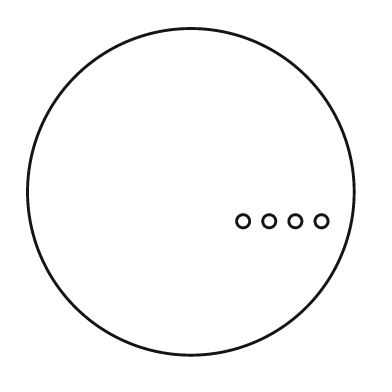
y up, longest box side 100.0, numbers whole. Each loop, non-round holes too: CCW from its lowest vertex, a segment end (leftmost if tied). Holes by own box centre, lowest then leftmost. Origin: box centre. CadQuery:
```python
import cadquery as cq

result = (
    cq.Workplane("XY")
    .moveTo(0.0, 0.0)
    .circle(50.0)
    .moveTo(16.0, -9.0)
    .circle(2.0)
    .moveTo(24.0, -9.0)
    .circle(2.0)
    .moveTo(32.0, -9.0)
    .circle(2.0)
    .moveTo(40.0, -9.0)
    .circle(2.0)
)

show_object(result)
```